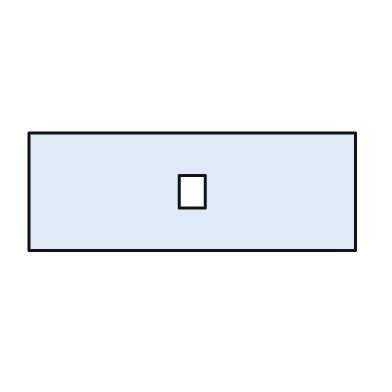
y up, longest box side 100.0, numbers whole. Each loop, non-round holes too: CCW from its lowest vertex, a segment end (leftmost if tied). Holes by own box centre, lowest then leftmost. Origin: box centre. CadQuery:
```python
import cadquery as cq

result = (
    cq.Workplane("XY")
    .moveTo(-50.0, -18.0)
    .lineTo(50.0, -18.0)
    .lineTo(50.0, 18.0)
    .lineTo(-50.0, 18.0)
    .close()
    .moveTo(-4.0, -5.0)
    .lineTo(4.0, -5.0)
    .lineTo(4.0, 5.0)
    .lineTo(-4.0, 5.0)
    .close()
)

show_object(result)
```